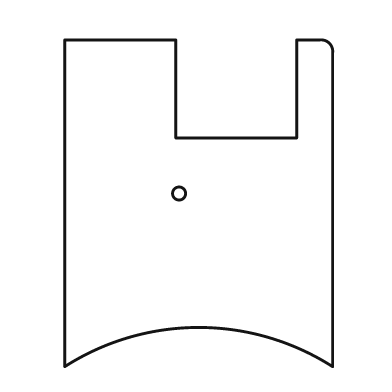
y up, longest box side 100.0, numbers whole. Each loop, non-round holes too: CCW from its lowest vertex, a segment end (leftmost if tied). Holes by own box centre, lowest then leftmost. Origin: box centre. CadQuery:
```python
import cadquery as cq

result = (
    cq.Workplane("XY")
    .moveTo(-41.0, -50.0)
    .threePointArc((0.0, -38.0), (41.0, -50.0))
    .lineTo(41.0, 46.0)
    .threePointArc((40.0, 49.0), (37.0, 50.0))
    .lineTo(30.0, 50.0)
    .lineTo(30.0, 20.0)
    .lineTo(-7.0, 20.0)
    .lineTo(-7.0, 50.0)
    .lineTo(-41.0, 50.0)
    .close()
    .moveTo(-6.0, 3.0)
    .circle(2.0)
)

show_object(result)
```